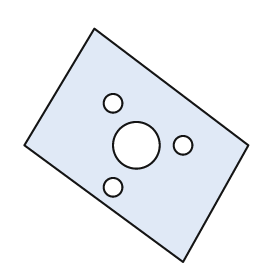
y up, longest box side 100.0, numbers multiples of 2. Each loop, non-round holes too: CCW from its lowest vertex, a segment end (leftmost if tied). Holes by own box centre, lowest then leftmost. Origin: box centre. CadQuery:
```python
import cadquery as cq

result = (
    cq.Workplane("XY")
    .moveTo(20.0, -50.0)
    .lineTo(48.0, 0.0)
    .lineTo(-18.0, 50.0)
    .lineTo(-48.0, 0.0)
    .close()
    .moveTo(-10.0, -18.0)
    .circle(4.0)
    .moveTo(0.0, 0.0)
    .circle(10.0)
    .moveTo(20.0, 0.0)
    .circle(4.0)
    .moveTo(-10.0, 18.0)
    .circle(4.0)
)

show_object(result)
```